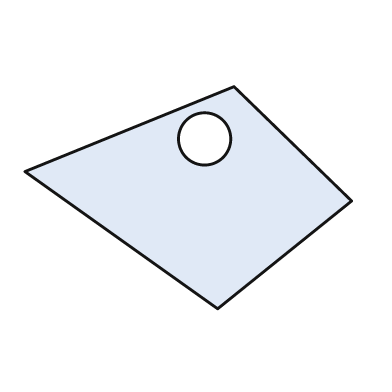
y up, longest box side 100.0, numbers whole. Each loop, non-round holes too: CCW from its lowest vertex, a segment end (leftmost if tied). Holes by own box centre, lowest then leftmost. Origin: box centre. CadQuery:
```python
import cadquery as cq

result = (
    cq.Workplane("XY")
    .moveTo(9.0, -34.0)
    .lineTo(50.0, -1.0)
    .lineTo(14.0, 34.0)
    .lineTo(-50.0, 8.0)
    .close()
    .moveTo(5.0, 18.0)
    .circle(8.0)
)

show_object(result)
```